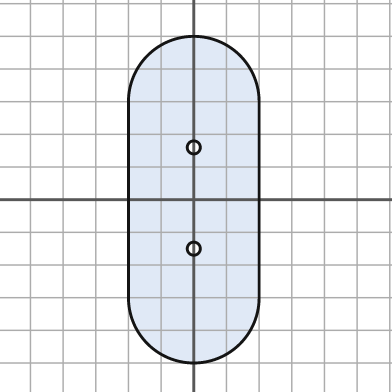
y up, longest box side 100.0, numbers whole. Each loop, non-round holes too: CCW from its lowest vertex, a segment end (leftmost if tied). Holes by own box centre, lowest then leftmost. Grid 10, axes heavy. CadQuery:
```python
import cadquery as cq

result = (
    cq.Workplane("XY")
    .moveTo(-20.0, -30.0)
    .threePointArc((0.0, -50.0), (20.0, -30.0))
    .lineTo(20.0, 30.0)
    .threePointArc((0.0, 50.0), (-20.0, 30.0))
    .close()
    .moveTo(0.0, -15.0)
    .circle(2.0)
    .moveTo(0.0, 16.0)
    .circle(2.0)
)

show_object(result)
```